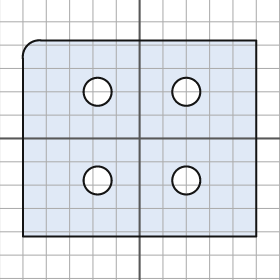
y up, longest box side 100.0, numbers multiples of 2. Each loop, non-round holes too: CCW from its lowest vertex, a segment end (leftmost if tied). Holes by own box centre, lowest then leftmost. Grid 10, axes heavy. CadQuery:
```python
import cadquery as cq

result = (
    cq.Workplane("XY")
    .moveTo(-50.0, -42.0)
    .lineTo(50.0, -42.0)
    .lineTo(50.0, 42.0)
    .lineTo(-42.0, 42.0)
    .threePointArc((-48.0, 40.0), (-50.0, 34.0))
    .close()
    .moveTo(-18.0, -18.0)
    .circle(6.0)
    .moveTo(20.0, -18.0)
    .circle(6.0)
    .moveTo(-18.0, 20.0)
    .circle(6.0)
    .moveTo(20.0, 20.0)
    .circle(6.0)
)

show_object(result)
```